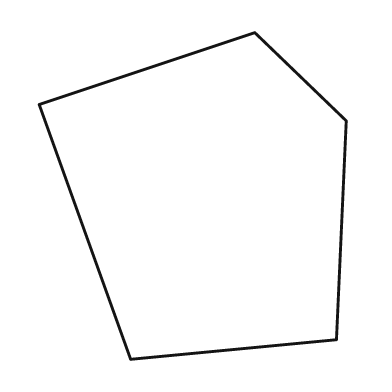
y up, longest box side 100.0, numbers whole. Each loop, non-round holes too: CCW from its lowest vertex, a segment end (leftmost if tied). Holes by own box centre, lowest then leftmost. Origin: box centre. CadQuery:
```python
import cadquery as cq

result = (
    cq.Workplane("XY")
    .moveTo(-19.0, -50.0)
    .lineTo(44.0, -44.0)
    .lineTo(47.0, 23.0)
    .lineTo(19.0, 50.0)
    .lineTo(-47.0, 28.0)
    .close()
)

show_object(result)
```